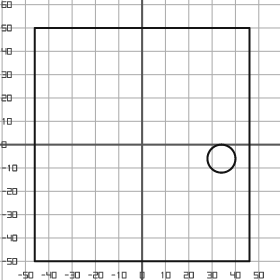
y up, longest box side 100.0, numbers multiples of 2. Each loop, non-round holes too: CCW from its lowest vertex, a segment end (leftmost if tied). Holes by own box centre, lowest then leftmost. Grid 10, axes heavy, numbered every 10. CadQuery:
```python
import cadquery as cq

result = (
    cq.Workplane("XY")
    .moveTo(-46.0, -50.0)
    .lineTo(46.0, -50.0)
    .lineTo(46.0, 50.0)
    .lineTo(-46.0, 50.0)
    .close()
    .moveTo(34.0, -6.0)
    .circle(6.0)
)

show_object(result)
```